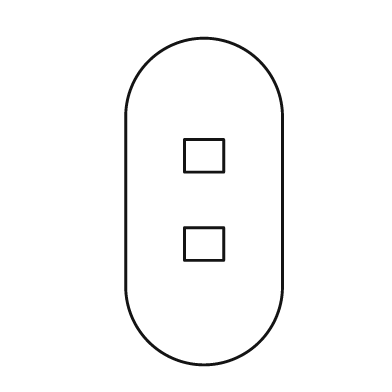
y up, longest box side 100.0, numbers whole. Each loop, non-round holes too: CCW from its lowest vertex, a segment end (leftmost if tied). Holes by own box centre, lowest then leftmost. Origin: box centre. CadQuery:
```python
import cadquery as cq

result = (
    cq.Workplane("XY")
    .moveTo(-24.0, -26.0)
    .threePointArc((0.0, -50.0), (24.0, -26.0))
    .lineTo(24.0, 26.0)
    .threePointArc((0.0, 50.0), (-24.0, 26.0))
    .close()
    .moveTo(-6.0, -18.0)
    .lineTo(6.0, -18.0)
    .lineTo(6.0, -8.0)
    .lineTo(-6.0, -8.0)
    .close()
    .moveTo(-6.0, 9.0)
    .lineTo(6.0, 9.0)
    .lineTo(6.0, 19.0)
    .lineTo(-6.0, 19.0)
    .close()
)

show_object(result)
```